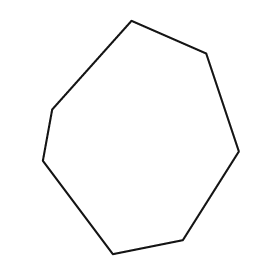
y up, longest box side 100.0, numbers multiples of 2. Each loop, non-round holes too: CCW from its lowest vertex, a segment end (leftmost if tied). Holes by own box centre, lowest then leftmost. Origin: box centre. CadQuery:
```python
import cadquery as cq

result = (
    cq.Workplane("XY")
    .moveTo(-12.0, -50.0)
    .lineTo(18.0, -44.0)
    .lineTo(42.0, -6.0)
    .lineTo(28.0, 36.0)
    .lineTo(-4.0, 50.0)
    .lineTo(-38.0, 12.0)
    .lineTo(-42.0, -10.0)
    .close()
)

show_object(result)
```